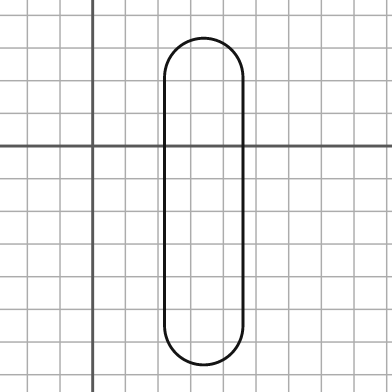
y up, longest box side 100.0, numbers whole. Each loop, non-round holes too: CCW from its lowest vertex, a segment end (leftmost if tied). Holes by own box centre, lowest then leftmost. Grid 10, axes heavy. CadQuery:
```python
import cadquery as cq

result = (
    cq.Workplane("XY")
    .moveTo(22.0, -55.0)
    .threePointArc((34.0, -67.0), (46.0, -55.0))
    .lineTo(46.0, 21.0)
    .threePointArc((34.0, 33.0), (22.0, 21.0))
    .close()
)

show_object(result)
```